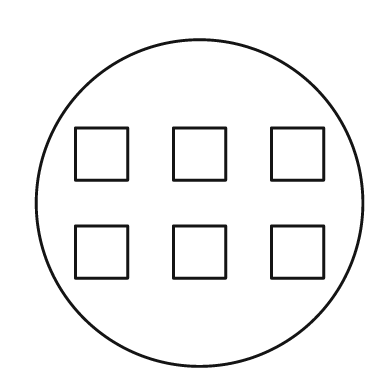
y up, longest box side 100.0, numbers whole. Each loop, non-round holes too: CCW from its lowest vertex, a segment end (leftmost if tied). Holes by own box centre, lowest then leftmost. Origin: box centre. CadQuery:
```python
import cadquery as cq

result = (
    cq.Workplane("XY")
    .moveTo(0.0, 0.0)
    .circle(50.0)
    .moveTo(-38.0, -23.0)
    .lineTo(-22.0, -23.0)
    .lineTo(-22.0, -7.0)
    .lineTo(-38.0, -7.0)
    .close()
    .moveTo(-8.0, -23.0)
    .lineTo(8.0, -23.0)
    .lineTo(8.0, -7.0)
    .lineTo(-8.0, -7.0)
    .close()
    .moveTo(22.0, -23.0)
    .lineTo(38.0, -23.0)
    .lineTo(38.0, -7.0)
    .lineTo(22.0, -7.0)
    .close()
    .moveTo(-38.0, 7.0)
    .lineTo(-22.0, 7.0)
    .lineTo(-22.0, 23.0)
    .lineTo(-38.0, 23.0)
    .close()
    .moveTo(-8.0, 7.0)
    .lineTo(8.0, 7.0)
    .lineTo(8.0, 23.0)
    .lineTo(-8.0, 23.0)
    .close()
    .moveTo(22.0, 7.0)
    .lineTo(38.0, 7.0)
    .lineTo(38.0, 23.0)
    .lineTo(22.0, 23.0)
    .close()
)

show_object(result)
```